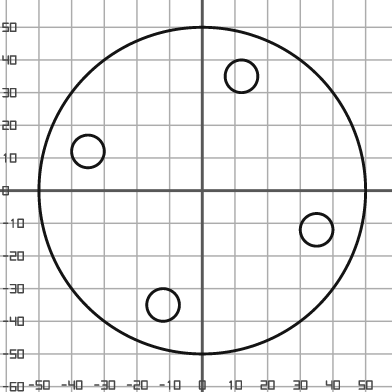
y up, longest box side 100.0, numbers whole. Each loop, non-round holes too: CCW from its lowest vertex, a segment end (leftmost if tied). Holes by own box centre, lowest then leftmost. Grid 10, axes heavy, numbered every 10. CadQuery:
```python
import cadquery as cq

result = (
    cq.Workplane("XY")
    .moveTo(0.0, 0.0)
    .circle(50.0)
    .moveTo(-12.0, -35.0)
    .circle(5.0)
    .moveTo(35.0, -12.0)
    .circle(5.0)
    .moveTo(-35.0, 12.0)
    .circle(5.0)
    .moveTo(12.0, 35.0)
    .circle(5.0)
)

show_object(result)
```